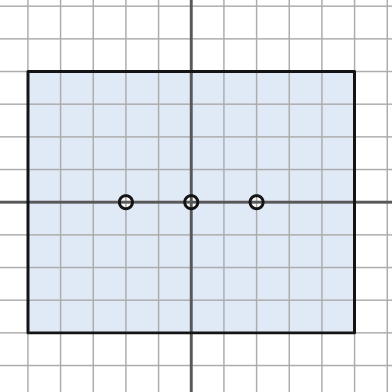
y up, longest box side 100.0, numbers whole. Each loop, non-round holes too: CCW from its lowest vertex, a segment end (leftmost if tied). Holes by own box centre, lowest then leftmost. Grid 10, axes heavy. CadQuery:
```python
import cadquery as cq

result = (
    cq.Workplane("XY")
    .moveTo(-50.0, -40.0)
    .lineTo(50.0, -40.0)
    .lineTo(50.0, 40.0)
    .lineTo(-50.0, 40.0)
    .close()
    .moveTo(-20.0, 0.0)
    .circle(2.0)
    .moveTo(0.0, 0.0)
    .circle(2.0)
    .moveTo(20.0, 0.0)
    .circle(2.0)
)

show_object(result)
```